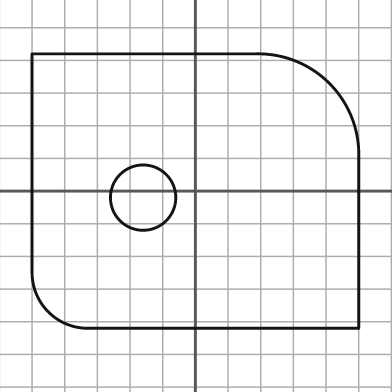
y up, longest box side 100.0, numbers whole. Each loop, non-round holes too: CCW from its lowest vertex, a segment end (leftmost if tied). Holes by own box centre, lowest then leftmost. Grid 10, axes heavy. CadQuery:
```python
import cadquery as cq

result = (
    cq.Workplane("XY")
    .moveTo(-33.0, -42.0)
    .lineTo(50.0, -42.0)
    .lineTo(50.0, 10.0)
    .threePointArc((41.0, 33.0), (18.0, 42.0))
    .lineTo(-50.0, 42.0)
    .lineTo(-50.0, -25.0)
    .threePointArc((-45.0, -37.0), (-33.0, -42.0))
    .close()
    .moveTo(-16.0, -2.0)
    .circle(10.0)
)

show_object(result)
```